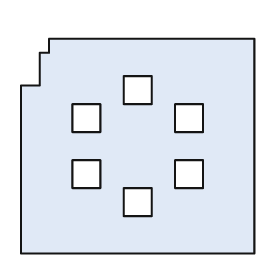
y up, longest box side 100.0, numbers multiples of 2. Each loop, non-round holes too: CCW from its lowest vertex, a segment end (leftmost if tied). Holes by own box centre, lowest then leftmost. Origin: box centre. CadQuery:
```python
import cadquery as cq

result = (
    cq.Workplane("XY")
    .moveTo(-50.0, -46.0)
    .lineTo(50.0, -46.0)
    .lineTo(50.0, 46.0)
    .lineTo(-38.0, 46.0)
    .lineTo(-38.0, 40.0)
    .lineTo(-42.0, 40.0)
    .lineTo(-42.0, 26.0)
    .lineTo(-50.0, 26.0)
    .close()
    .moveTo(-6.0, -30.0)
    .lineTo(6.0, -30.0)
    .lineTo(6.0, -18.0)
    .lineTo(-6.0, -18.0)
    .close()
    .moveTo(-28.0, -18.0)
    .lineTo(-16.0, -18.0)
    .lineTo(-16.0, -6.0)
    .lineTo(-28.0, -6.0)
    .close()
    .moveTo(16.0, -18.0)
    .lineTo(28.0, -18.0)
    .lineTo(28.0, -6.0)
    .lineTo(16.0, -6.0)
    .close()
    .moveTo(-28.0, 6.0)
    .lineTo(-16.0, 6.0)
    .lineTo(-16.0, 18.0)
    .lineTo(-28.0, 18.0)
    .close()
    .moveTo(16.0, 6.0)
    .lineTo(28.0, 6.0)
    .lineTo(28.0, 18.0)
    .lineTo(16.0, 18.0)
    .close()
    .moveTo(-6.0, 18.0)
    .lineTo(6.0, 18.0)
    .lineTo(6.0, 30.0)
    .lineTo(-6.0, 30.0)
    .close()
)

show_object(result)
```